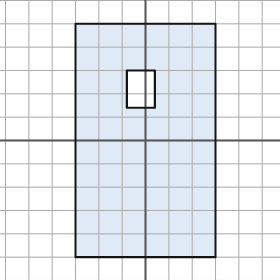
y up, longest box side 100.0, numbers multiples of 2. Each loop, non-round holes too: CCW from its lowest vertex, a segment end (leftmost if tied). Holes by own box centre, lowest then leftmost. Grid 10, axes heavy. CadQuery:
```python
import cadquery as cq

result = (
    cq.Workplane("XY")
    .moveTo(-30.0, -50.0)
    .lineTo(30.0, -50.0)
    .lineTo(30.0, 50.0)
    .lineTo(-30.0, 50.0)
    .close()
    .moveTo(-8.0, 14.0)
    .lineTo(4.0, 14.0)
    .lineTo(4.0, 30.0)
    .lineTo(-8.0, 30.0)
    .close()
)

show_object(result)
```